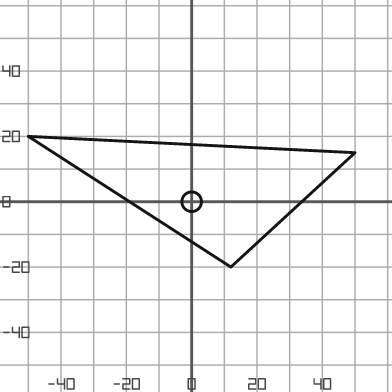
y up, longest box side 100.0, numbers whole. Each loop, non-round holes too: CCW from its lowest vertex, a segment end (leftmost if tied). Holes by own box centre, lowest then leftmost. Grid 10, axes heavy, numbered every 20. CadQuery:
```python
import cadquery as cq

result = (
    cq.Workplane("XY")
    .moveTo(12.0, -20.0)
    .lineTo(50.0, 15.0)
    .lineTo(-50.0, 20.0)
    .close()
    .moveTo(0.0, 0.0)
    .circle(3.0)
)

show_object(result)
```